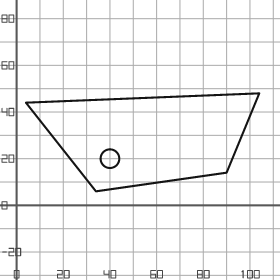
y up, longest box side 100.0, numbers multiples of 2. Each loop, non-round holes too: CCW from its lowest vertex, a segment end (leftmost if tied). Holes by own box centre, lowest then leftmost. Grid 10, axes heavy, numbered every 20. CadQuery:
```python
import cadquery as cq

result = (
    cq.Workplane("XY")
    .moveTo(34.0, 6.0)
    .lineTo(90.0, 14.0)
    .lineTo(104.0, 48.0)
    .lineTo(4.0, 44.0)
    .close()
    .moveTo(40.0, 20.0)
    .circle(4.0)
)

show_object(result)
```